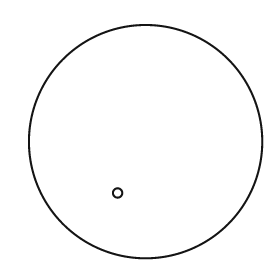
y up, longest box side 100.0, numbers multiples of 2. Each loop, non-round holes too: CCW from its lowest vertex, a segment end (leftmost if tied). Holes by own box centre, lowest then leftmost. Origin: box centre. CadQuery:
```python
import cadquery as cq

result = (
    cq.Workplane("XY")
    .moveTo(0.0, 0.0)
    .circle(50.0)
    .moveTo(-12.0, -22.0)
    .circle(2.0)
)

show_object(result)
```